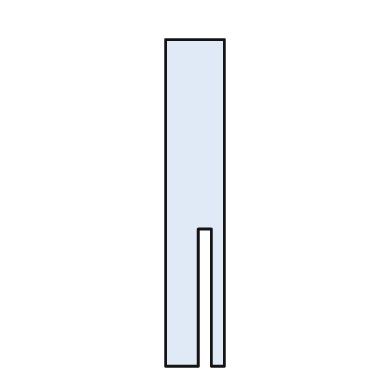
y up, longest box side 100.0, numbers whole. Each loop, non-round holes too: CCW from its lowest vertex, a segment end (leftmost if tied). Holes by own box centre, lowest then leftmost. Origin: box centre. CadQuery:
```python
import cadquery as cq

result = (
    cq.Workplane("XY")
    .moveTo(-9.0, -50.0)
    .lineTo(1.0, -50.0)
    .lineTo(1.0, -8.0)
    .lineTo(5.0, -8.0)
    .lineTo(5.0, -50.0)
    .lineTo(9.0, -50.0)
    .lineTo(9.0, 50.0)
    .lineTo(-9.0, 50.0)
    .close()
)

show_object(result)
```